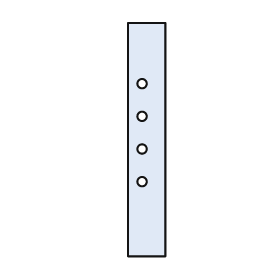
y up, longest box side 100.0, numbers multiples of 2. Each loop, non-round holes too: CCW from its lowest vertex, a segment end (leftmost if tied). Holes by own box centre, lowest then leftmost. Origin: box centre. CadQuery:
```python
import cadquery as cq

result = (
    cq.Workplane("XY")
    .moveTo(-8.0, -50.0)
    .lineTo(8.0, -50.0)
    .lineTo(8.0, 50.0)
    .lineTo(-8.0, 50.0)
    .close()
    .moveTo(-2.0, -18.0)
    .circle(2.0)
    .moveTo(-2.0, -4.0)
    .circle(2.0)
    .moveTo(-2.0, 10.0)
    .circle(2.0)
    .moveTo(-2.0, 24.0)
    .circle(2.0)
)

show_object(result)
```